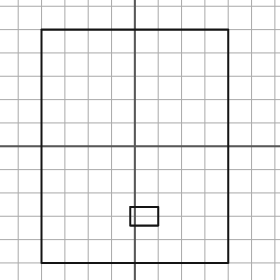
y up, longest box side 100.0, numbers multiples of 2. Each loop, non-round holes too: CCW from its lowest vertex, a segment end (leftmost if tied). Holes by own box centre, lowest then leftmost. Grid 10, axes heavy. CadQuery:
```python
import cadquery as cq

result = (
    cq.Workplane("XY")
    .moveTo(-40.0, -50.0)
    .lineTo(40.0, -50.0)
    .lineTo(40.0, 50.0)
    .lineTo(-40.0, 50.0)
    .close()
    .moveTo(-2.0, -34.0)
    .lineTo(10.0, -34.0)
    .lineTo(10.0, -26.0)
    .lineTo(-2.0, -26.0)
    .close()
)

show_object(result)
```